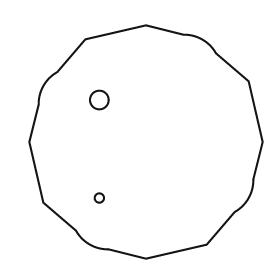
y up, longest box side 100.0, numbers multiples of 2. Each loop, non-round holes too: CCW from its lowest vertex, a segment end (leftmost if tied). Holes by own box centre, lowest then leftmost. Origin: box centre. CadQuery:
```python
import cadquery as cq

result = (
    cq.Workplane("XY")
    .moveTo(0.0, -50.0)
    .lineTo(26.0, -44.0)
    .lineTo(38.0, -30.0)
    .threePointArc((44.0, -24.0), (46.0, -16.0))
    .lineTo(50.0, 0.0)
    .lineTo(44.0, 26.0)
    .lineTo(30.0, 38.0)
    .threePointArc((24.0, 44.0), (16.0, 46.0))
    .lineTo(0.0, 50.0)
    .lineTo(-26.0, 44.0)
    .lineTo(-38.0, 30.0)
    .threePointArc((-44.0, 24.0), (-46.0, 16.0))
    .lineTo(-50.0, 0.0)
    .lineTo(-44.0, -26.0)
    .lineTo(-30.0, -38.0)
    .threePointArc((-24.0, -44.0), (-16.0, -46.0))
    .close()
    .moveTo(-20.0, -24.0)
    .circle(2.0)
    .moveTo(-20.0, 18.0)
    .circle(4.0)
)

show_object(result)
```